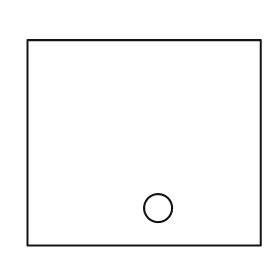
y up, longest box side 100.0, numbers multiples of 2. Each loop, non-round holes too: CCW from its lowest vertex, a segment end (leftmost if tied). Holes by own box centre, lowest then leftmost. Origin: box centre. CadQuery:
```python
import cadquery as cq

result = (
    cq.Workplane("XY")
    .moveTo(-50.0, -44.0)
    .lineTo(50.0, -44.0)
    .lineTo(50.0, 44.0)
    .lineTo(-50.0, 44.0)
    .close()
    .moveTo(6.0, -28.0)
    .circle(6.0)
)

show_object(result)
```